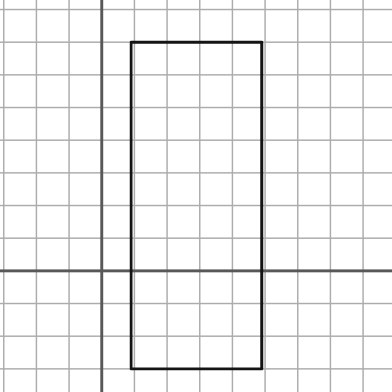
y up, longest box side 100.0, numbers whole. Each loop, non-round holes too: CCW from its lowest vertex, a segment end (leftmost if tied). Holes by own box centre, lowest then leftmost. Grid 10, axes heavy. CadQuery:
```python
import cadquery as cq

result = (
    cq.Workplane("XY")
    .moveTo(9.0, -30.0)
    .lineTo(49.0, -30.0)
    .lineTo(49.0, 70.0)
    .lineTo(9.0, 70.0)
    .close()
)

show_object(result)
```